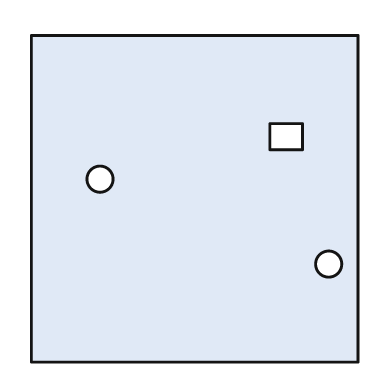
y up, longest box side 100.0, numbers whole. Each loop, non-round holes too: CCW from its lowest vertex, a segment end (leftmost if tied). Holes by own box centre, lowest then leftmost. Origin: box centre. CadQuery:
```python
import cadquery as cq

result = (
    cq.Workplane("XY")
    .moveTo(-50.0, -50.0)
    .lineTo(50.0, -50.0)
    .lineTo(50.0, 50.0)
    .lineTo(-50.0, 50.0)
    .close()
    .moveTo(41.0, -20.0)
    .circle(4.0)
    .moveTo(-29.0, 6.0)
    .circle(4.0)
    .moveTo(23.0, 15.0)
    .lineTo(33.0, 15.0)
    .lineTo(33.0, 23.0)
    .lineTo(23.0, 23.0)
    .close()
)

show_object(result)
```